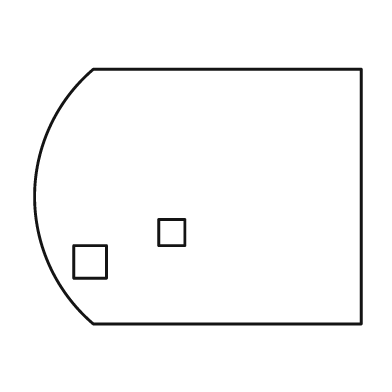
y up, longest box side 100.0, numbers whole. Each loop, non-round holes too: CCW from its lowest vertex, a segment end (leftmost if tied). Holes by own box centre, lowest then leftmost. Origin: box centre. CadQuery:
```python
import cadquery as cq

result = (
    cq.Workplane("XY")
    .moveTo(-32.0, -39.0)
    .lineTo(50.0, -39.0)
    .lineTo(50.0, 39.0)
    .lineTo(-32.0, 39.0)
    .threePointArc((-50.0, 0.0), (-32.0, -39.0))
    .close()
    .moveTo(-38.0, -25.0)
    .lineTo(-28.0, -25.0)
    .lineTo(-28.0, -15.0)
    .lineTo(-38.0, -15.0)
    .close()
    .moveTo(-12.0, -15.0)
    .lineTo(-4.0, -15.0)
    .lineTo(-4.0, -7.0)
    .lineTo(-12.0, -7.0)
    .close()
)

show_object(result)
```